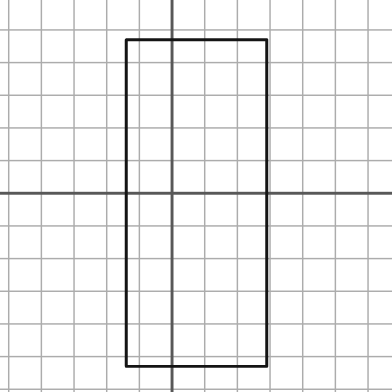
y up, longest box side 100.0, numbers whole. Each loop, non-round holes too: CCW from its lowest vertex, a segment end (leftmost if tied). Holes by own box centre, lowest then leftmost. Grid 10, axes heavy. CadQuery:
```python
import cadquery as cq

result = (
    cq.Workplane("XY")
    .moveTo(-14.0, -53.0)
    .lineTo(29.0, -53.0)
    .lineTo(29.0, 47.0)
    .lineTo(-14.0, 47.0)
    .close()
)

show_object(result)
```